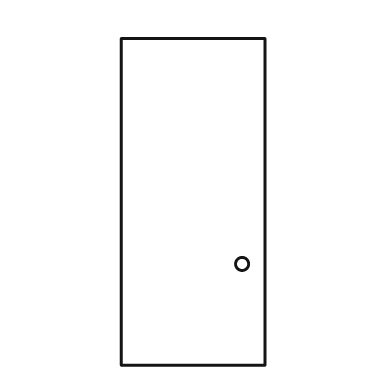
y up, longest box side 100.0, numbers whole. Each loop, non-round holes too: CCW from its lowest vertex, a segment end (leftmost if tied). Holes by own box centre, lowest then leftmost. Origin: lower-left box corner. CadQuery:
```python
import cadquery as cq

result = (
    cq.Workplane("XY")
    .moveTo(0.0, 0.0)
    .lineTo(44.0, 0.0)
    .lineTo(44.0, 100.0)
    .lineTo(0.0, 100.0)
    .close()
    .moveTo(37.0, 31.0)
    .circle(2.0)
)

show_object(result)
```